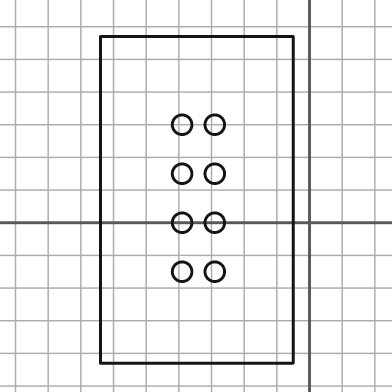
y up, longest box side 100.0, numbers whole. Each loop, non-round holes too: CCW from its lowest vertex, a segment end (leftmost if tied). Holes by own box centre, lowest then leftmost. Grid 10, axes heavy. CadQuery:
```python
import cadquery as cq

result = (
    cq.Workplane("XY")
    .moveTo(-64.0, -43.0)
    .lineTo(-5.0, -43.0)
    .lineTo(-5.0, 57.0)
    .lineTo(-64.0, 57.0)
    .close()
    .moveTo(-39.0, -15.0)
    .circle(3.0)
    .moveTo(-29.0, -15.0)
    .circle(3.0)
    .moveTo(-39.0, 0.0)
    .circle(3.0)
    .moveTo(-29.0, 0.0)
    .circle(3.0)
    .moveTo(-39.0, 15.0)
    .circle(3.0)
    .moveTo(-29.0, 15.0)
    .circle(3.0)
    .moveTo(-39.0, 30.0)
    .circle(3.0)
    .moveTo(-29.0, 30.0)
    .circle(3.0)
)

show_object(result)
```